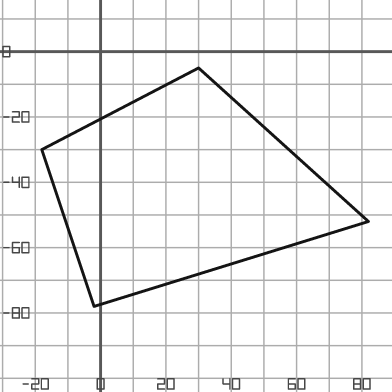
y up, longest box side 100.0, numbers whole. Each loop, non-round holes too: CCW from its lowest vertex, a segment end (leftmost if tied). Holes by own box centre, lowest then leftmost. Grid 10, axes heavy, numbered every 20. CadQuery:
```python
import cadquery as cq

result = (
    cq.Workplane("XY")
    .moveTo(-2.0, -78.0)
    .lineTo(82.0, -52.0)
    .lineTo(30.0, -5.0)
    .lineTo(-18.0, -30.0)
    .close()
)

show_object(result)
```